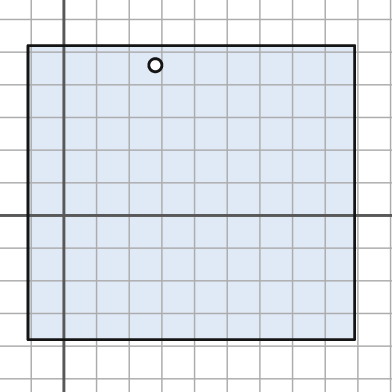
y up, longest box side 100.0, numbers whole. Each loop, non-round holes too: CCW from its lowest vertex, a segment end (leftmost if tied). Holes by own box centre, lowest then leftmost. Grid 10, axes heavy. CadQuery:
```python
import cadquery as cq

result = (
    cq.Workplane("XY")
    .moveTo(-11.0, -38.0)
    .lineTo(89.0, -38.0)
    .lineTo(89.0, 52.0)
    .lineTo(-11.0, 52.0)
    .close()
    .moveTo(28.0, 46.0)
    .circle(2.0)
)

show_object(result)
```